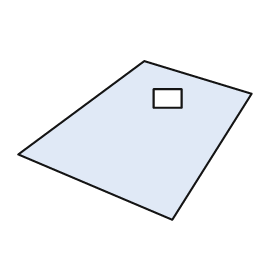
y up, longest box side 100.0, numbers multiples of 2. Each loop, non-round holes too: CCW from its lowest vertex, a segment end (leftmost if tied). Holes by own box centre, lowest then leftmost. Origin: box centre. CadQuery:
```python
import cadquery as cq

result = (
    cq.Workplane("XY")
    .moveTo(16.0, -34.0)
    .lineTo(50.0, 20.0)
    .lineTo(4.0, 34.0)
    .lineTo(-50.0, -6.0)
    .close()
    .moveTo(8.0, 14.0)
    .lineTo(20.0, 14.0)
    .lineTo(20.0, 22.0)
    .lineTo(8.0, 22.0)
    .close()
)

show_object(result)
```